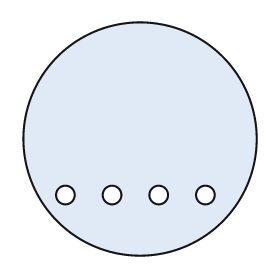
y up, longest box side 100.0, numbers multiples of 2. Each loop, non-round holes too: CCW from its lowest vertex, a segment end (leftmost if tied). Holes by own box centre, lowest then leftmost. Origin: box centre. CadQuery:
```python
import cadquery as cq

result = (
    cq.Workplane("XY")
    .moveTo(0.0, 0.0)
    .circle(50.0)
    .moveTo(-32.0, -24.0)
    .circle(4.0)
    .moveTo(-12.0, -24.0)
    .circle(4.0)
    .moveTo(8.0, -24.0)
    .circle(4.0)
    .moveTo(28.0, -24.0)
    .circle(4.0)
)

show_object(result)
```